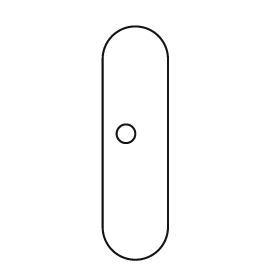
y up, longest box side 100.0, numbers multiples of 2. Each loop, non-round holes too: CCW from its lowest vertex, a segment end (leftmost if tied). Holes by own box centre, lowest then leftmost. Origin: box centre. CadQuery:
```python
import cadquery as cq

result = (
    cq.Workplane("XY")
    .moveTo(-14.0, -36.0)
    .threePointArc((0.0, -50.0), (14.0, -36.0))
    .lineTo(14.0, 36.0)
    .threePointArc((0.0, 50.0), (-14.0, 36.0))
    .close()
    .moveTo(-4.0, 4.0)
    .circle(4.0)
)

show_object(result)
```